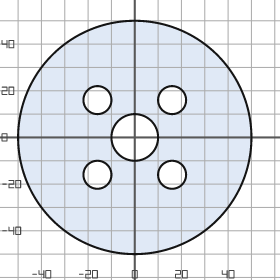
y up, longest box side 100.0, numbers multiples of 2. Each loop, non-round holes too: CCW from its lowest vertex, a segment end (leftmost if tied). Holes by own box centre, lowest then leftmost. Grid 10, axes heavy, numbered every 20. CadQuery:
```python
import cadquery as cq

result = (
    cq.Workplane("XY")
    .moveTo(0.0, 0.0)
    .circle(50.0)
    .moveTo(-16.0, -16.0)
    .circle(6.0)
    .moveTo(16.0, -16.0)
    .circle(6.0)
    .moveTo(0.0, 0.0)
    .circle(10.0)
    .moveTo(-16.0, 16.0)
    .circle(6.0)
    .moveTo(16.0, 16.0)
    .circle(6.0)
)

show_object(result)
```